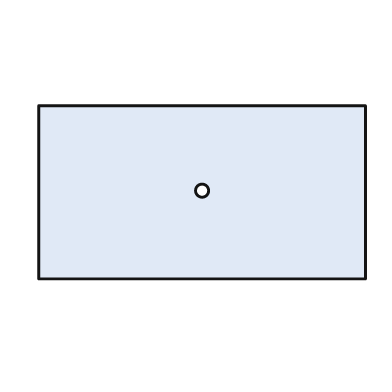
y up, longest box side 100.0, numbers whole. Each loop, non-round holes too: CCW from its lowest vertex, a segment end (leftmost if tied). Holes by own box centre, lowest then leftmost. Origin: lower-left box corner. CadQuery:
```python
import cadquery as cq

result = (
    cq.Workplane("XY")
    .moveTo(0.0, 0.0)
    .lineTo(100.0, 0.0)
    .lineTo(100.0, 53.0)
    .lineTo(0.0, 53.0)
    .close()
    .moveTo(50.0, 27.0)
    .circle(2.0)
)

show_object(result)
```